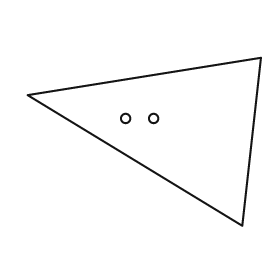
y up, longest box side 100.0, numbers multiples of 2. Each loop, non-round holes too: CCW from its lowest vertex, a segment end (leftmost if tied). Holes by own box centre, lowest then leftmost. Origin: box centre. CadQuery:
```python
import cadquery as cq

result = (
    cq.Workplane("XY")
    .moveTo(42.0, -36.0)
    .lineTo(50.0, 36.0)
    .lineTo(-50.0, 20.0)
    .close()
    .moveTo(-8.0, 10.0)
    .circle(2.0)
    .moveTo(4.0, 10.0)
    .circle(2.0)
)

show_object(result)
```